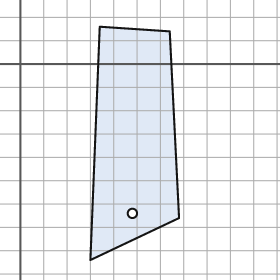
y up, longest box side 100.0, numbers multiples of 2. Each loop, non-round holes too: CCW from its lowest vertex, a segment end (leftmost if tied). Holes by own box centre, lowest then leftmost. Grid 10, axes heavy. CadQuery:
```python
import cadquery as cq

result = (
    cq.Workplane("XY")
    .moveTo(30.0, -84.0)
    .lineTo(68.0, -66.0)
    .lineTo(64.0, 14.0)
    .lineTo(34.0, 16.0)
    .close()
    .moveTo(48.0, -64.0)
    .circle(2.0)
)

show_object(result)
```